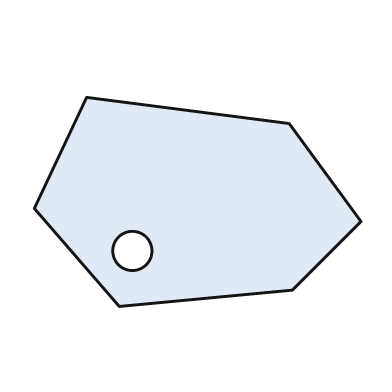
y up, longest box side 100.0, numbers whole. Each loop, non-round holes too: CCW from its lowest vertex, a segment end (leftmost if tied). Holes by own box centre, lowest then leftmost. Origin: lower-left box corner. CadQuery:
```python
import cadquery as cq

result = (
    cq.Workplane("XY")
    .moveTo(26.0, 0.0)
    .lineTo(79.0, 5.0)
    .lineTo(100.0, 26.0)
    .lineTo(78.0, 56.0)
    .lineTo(16.0, 64.0)
    .lineTo(0.0, 30.0)
    .close()
    .moveTo(30.0, 17.0)
    .circle(6.0)
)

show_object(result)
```